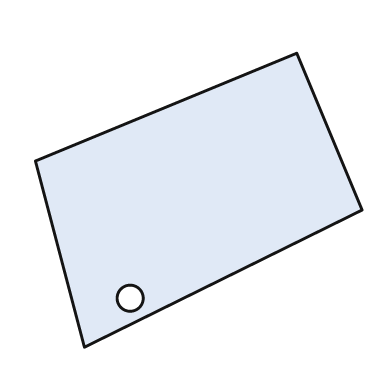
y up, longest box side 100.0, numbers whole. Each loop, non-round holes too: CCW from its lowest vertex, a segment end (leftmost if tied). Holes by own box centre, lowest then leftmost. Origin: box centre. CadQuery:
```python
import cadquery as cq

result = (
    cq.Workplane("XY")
    .moveTo(-35.0, -45.0)
    .lineTo(50.0, -3.0)
    .lineTo(30.0, 45.0)
    .lineTo(-50.0, 12.0)
    .close()
    .moveTo(-21.0, -30.0)
    .circle(4.0)
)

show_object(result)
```